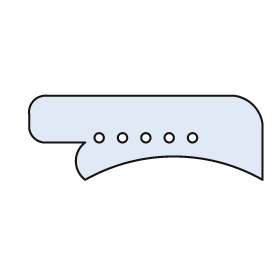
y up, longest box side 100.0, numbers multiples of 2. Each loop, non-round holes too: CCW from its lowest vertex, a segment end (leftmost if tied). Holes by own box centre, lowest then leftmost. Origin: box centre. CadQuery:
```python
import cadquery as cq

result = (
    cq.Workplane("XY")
    .moveTo(-26.0, -18.0)
    .threePointArc((12.0, -8.0), (50.0, -18.0))
    .lineTo(50.0, 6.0)
    .threePointArc((46.0, 14.0), (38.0, 18.0))
    .lineTo(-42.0, 18.0)
    .threePointArc((-48.0, 16.0), (-50.0, 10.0))
    .lineTo(-50.0, 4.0)
    .threePointArc((-48.0, 0.0), (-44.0, -2.0))
    .lineTo(-26.0, -2.0)
    .threePointArc((-30.0, -10.0), (-26.0, -18.0))
    .close()
    .moveTo(-20.0, 0.0)
    .circle(2.0)
    .moveTo(-10.0, 0.0)
    .circle(2.0)
    .moveTo(0.0, 0.0)
    .circle(2.0)
    .moveTo(10.0, 0.0)
    .circle(2.0)
    .moveTo(20.0, 0.0)
    .circle(2.0)
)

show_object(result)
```